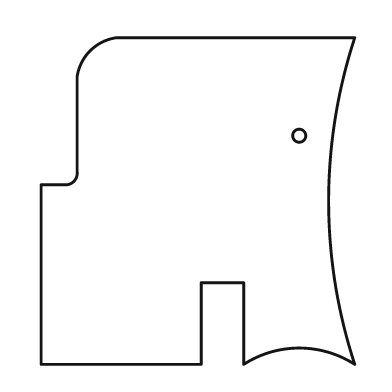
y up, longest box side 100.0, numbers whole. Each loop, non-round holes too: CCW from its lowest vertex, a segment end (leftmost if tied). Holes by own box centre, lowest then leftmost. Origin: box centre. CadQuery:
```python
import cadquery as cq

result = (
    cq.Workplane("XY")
    .moveTo(-48.0, -50.0)
    .lineTo(1.0, -50.0)
    .lineTo(1.0, -25.0)
    .lineTo(14.0, -25.0)
    .lineTo(14.0, -50.0)
    .threePointArc((31.0, -45.0), (48.0, -50.0))
    .threePointArc((40.0, 0.0), (48.0, 50.0))
    .lineTo(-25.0, 50.0)
    .threePointArc((-33.0, 46.0), (-37.0, 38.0))
    .lineTo(-37.0, 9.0)
    .threePointArc((-38.0, 6.0), (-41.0, 5.0))
    .lineTo(-48.0, 5.0)
    .close()
    .moveTo(31.0, 20.0)
    .circle(2.0)
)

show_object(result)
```